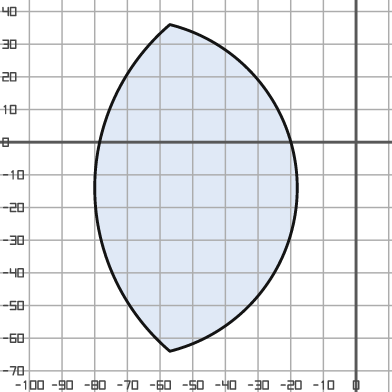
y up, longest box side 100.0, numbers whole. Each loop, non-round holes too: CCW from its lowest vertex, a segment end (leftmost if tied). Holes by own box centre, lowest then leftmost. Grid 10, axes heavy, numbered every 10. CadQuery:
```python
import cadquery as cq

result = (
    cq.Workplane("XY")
    .moveTo(-57.0, -64.0)
    .threePointArc((-18.0, -14.0), (-57.0, 36.0))
    .threePointArc((-80.0, -14.0), (-57.0, -64.0))
    .close()
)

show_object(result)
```